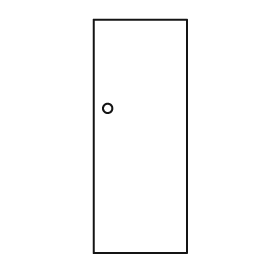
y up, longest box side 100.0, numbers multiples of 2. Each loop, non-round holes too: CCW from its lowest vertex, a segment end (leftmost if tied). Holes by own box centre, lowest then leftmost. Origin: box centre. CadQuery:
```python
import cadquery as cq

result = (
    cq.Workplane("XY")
    .moveTo(-20.0, -50.0)
    .lineTo(20.0, -50.0)
    .lineTo(20.0, 50.0)
    .lineTo(-20.0, 50.0)
    .close()
    .moveTo(-14.0, 12.0)
    .circle(2.0)
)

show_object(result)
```